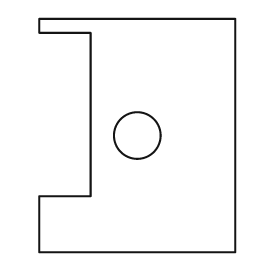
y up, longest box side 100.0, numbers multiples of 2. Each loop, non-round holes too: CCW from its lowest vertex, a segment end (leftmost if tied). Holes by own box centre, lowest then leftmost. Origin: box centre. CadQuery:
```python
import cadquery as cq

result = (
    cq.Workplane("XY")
    .moveTo(-42.0, -50.0)
    .lineTo(42.0, -50.0)
    .lineTo(42.0, 50.0)
    .lineTo(-42.0, 50.0)
    .lineTo(-42.0, 44.0)
    .lineTo(-20.0, 44.0)
    .lineTo(-20.0, -26.0)
    .lineTo(-42.0, -26.0)
    .close()
    .moveTo(0.0, 0.0)
    .circle(10.0)
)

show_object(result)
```